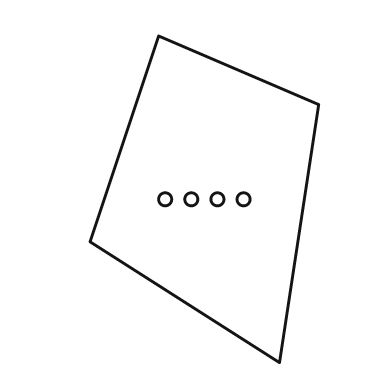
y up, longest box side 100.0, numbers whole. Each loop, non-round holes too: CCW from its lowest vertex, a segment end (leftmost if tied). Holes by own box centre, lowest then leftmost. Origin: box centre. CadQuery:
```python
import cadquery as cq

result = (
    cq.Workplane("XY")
    .moveTo(23.0, -50.0)
    .lineTo(35.0, 29.0)
    .lineTo(-14.0, 50.0)
    .lineTo(-35.0, -13.0)
    .close()
    .moveTo(-12.0, 0.0)
    .circle(2.0)
    .moveTo(-4.0, 0.0)
    .circle(2.0)
    .moveTo(4.0, 0.0)
    .circle(2.0)
    .moveTo(12.0, 0.0)
    .circle(2.0)
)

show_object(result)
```